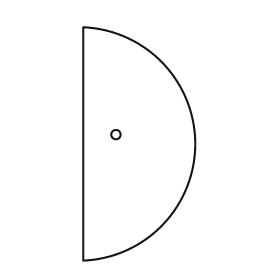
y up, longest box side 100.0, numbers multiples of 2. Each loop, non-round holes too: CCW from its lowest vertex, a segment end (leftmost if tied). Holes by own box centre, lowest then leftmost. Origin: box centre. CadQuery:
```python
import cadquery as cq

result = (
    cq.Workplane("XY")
    .moveTo(-24.0, -50.0)
    .threePointArc((24.0, 0.0), (-24.0, 50.0))
    .close()
    .moveTo(-10.0, 4.0)
    .circle(2.0)
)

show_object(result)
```